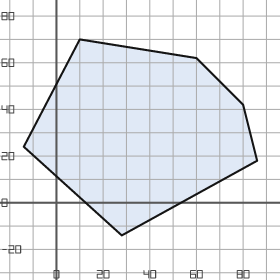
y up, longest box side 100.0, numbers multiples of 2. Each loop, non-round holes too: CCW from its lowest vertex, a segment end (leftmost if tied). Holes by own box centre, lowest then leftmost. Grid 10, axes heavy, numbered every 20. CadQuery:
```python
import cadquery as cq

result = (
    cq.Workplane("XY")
    .moveTo(28.0, -14.0)
    .lineTo(86.0, 18.0)
    .lineTo(80.0, 42.0)
    .lineTo(60.0, 62.0)
    .lineTo(10.0, 70.0)
    .lineTo(-14.0, 24.0)
    .close()
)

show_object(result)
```